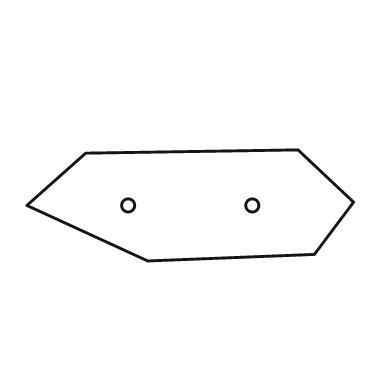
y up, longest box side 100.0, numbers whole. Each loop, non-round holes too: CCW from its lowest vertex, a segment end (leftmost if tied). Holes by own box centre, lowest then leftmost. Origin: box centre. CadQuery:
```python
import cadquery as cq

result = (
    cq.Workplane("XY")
    .moveTo(-13.0, -17.0)
    .lineTo(38.0, -15.0)
    .lineTo(50.0, 1.0)
    .lineTo(33.0, 17.0)
    .lineTo(-32.0, 16.0)
    .lineTo(-50.0, 0.0)
    .close()
    .moveTo(-19.0, 0.0)
    .circle(2.0)
    .moveTo(19.0, 0.0)
    .circle(2.0)
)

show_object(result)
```